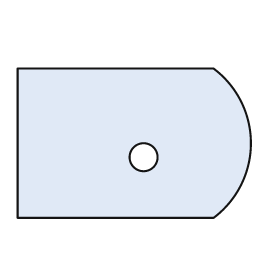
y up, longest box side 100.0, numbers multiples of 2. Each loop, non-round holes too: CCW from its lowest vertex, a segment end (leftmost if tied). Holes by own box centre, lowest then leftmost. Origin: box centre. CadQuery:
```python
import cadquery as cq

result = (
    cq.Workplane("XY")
    .moveTo(-50.0, -32.0)
    .lineTo(34.0, -32.0)
    .threePointArc((50.0, 0.0), (34.0, 32.0))
    .lineTo(-50.0, 32.0)
    .close()
    .moveTo(4.0, -6.0)
    .circle(6.0)
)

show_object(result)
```